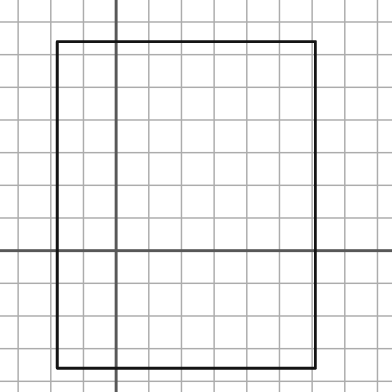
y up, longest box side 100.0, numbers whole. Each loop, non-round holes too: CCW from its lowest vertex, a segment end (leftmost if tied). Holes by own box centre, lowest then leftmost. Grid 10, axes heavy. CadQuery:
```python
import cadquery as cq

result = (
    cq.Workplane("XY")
    .moveTo(-18.0, -36.0)
    .lineTo(61.0, -36.0)
    .lineTo(61.0, 64.0)
    .lineTo(-18.0, 64.0)
    .close()
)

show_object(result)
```